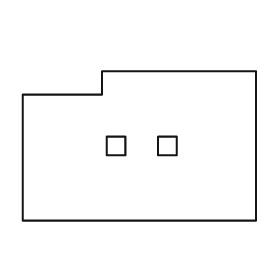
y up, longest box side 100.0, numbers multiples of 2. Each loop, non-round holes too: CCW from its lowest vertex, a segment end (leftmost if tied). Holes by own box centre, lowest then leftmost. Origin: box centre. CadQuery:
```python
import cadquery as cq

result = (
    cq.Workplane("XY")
    .moveTo(-50.0, -32.0)
    .lineTo(50.0, -32.0)
    .lineTo(50.0, 32.0)
    .lineTo(-16.0, 32.0)
    .lineTo(-16.0, 22.0)
    .lineTo(-50.0, 22.0)
    .close()
    .moveTo(-14.0, -4.0)
    .lineTo(-6.0, -4.0)
    .lineTo(-6.0, 4.0)
    .lineTo(-14.0, 4.0)
    .close()
    .moveTo(8.0, -4.0)
    .lineTo(16.0, -4.0)
    .lineTo(16.0, 4.0)
    .lineTo(8.0, 4.0)
    .close()
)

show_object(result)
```